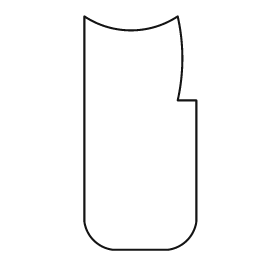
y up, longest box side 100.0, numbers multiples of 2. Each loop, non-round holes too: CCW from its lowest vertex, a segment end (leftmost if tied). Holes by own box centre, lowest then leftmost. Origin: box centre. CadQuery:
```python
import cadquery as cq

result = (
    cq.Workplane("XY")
    .moveTo(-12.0, -50.0)
    .lineTo(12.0, -50.0)
    .threePointArc((20.0, -46.0), (24.0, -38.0))
    .lineTo(24.0, 14.0)
    .lineTo(16.0, 14.0)
    .threePointArc((18.0, 32.0), (16.0, 50.0))
    .threePointArc((-4.0, 44.0), (-24.0, 50.0))
    .lineTo(-24.0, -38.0)
    .threePointArc((-20.0, -46.0), (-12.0, -50.0))
    .close()
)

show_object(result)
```